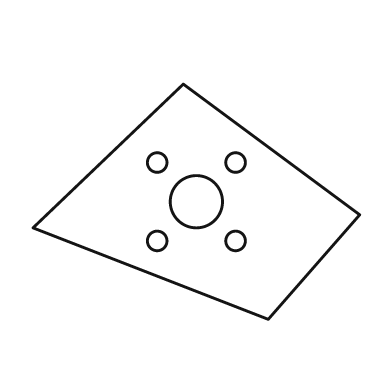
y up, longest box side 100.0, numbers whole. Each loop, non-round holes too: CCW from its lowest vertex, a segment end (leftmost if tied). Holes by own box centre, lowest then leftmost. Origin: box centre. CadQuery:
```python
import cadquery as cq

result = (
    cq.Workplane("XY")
    .moveTo(22.0, -36.0)
    .lineTo(50.0, -4.0)
    .lineTo(-4.0, 36.0)
    .lineTo(-50.0, -8.0)
    .close()
    .moveTo(-12.0, -12.0)
    .circle(3.0)
    .moveTo(12.0, -12.0)
    .circle(3.0)
    .moveTo(0.0, 0.0)
    .circle(8.0)
    .moveTo(-12.0, 12.0)
    .circle(3.0)
    .moveTo(12.0, 12.0)
    .circle(3.0)
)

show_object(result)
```